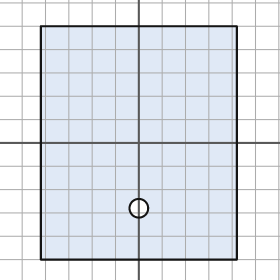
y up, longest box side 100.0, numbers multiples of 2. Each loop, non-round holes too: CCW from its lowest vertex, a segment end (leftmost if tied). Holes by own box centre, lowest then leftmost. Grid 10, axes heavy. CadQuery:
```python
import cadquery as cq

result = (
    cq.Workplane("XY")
    .moveTo(-42.0, -50.0)
    .lineTo(42.0, -50.0)
    .lineTo(42.0, 50.0)
    .lineTo(-42.0, 50.0)
    .close()
    .moveTo(0.0, -28.0)
    .circle(4.0)
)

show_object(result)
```